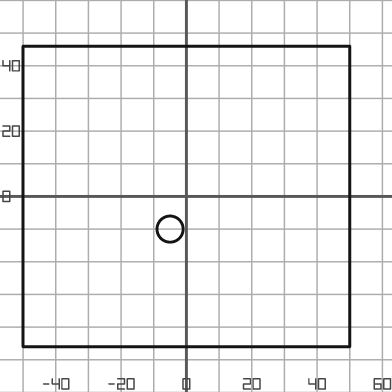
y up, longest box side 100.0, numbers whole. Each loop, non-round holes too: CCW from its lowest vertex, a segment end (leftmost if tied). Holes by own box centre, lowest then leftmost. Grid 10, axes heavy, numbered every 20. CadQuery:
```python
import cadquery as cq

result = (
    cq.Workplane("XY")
    .moveTo(-50.0, -46.0)
    .lineTo(50.0, -46.0)
    .lineTo(50.0, 46.0)
    .lineTo(-50.0, 46.0)
    .close()
    .moveTo(-5.0, -10.0)
    .circle(4.0)
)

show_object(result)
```